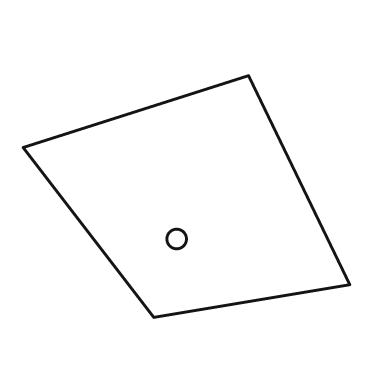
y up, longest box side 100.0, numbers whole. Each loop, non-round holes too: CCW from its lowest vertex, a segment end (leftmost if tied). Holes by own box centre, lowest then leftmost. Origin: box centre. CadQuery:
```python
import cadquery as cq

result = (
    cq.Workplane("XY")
    .moveTo(-10.0, -37.0)
    .lineTo(50.0, -27.0)
    .lineTo(19.0, 37.0)
    .lineTo(-50.0, 15.0)
    .close()
    .moveTo(-3.0, -13.0)
    .circle(3.0)
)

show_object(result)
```